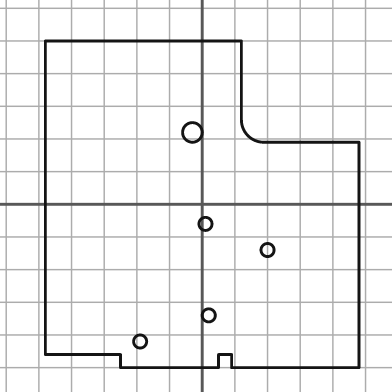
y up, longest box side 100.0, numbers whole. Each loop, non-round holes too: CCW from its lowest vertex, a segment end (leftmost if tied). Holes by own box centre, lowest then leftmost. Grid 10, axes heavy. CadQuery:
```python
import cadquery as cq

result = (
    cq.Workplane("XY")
    .moveTo(-25.0, -50.0)
    .lineTo(5.0, -50.0)
    .lineTo(5.0, -46.0)
    .lineTo(9.0, -46.0)
    .lineTo(9.0, -50.0)
    .lineTo(48.0, -50.0)
    .lineTo(48.0, 19.0)
    .lineTo(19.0, 19.0)
    .threePointArc((14.0, 21.0), (12.0, 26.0))
    .lineTo(12.0, 50.0)
    .lineTo(-48.0, 50.0)
    .lineTo(-48.0, -46.0)
    .lineTo(-25.0, -46.0)
    .close()
    .moveTo(-19.0, -42.0)
    .circle(2.0)
    .moveTo(2.0, -34.0)
    .circle(2.0)
    .moveTo(20.0, -14.0)
    .circle(2.0)
    .moveTo(1.0, -6.0)
    .circle(2.0)
    .moveTo(-3.0, 22.0)
    .circle(3.0)
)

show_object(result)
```